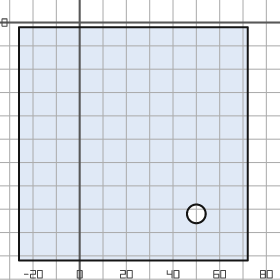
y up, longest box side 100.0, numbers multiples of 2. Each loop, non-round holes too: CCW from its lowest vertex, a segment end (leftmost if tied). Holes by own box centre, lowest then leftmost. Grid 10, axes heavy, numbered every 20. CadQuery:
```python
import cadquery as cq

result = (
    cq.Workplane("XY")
    .moveTo(-26.0, -102.0)
    .lineTo(72.0, -102.0)
    .lineTo(72.0, -2.0)
    .lineTo(-26.0, -2.0)
    .close()
    .moveTo(50.0, -82.0)
    .circle(4.0)
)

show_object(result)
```